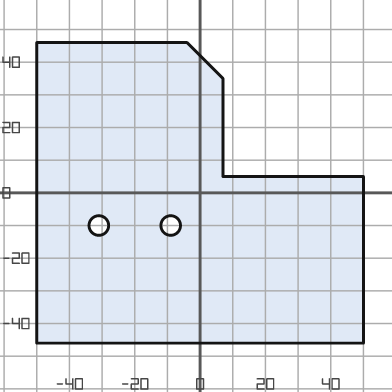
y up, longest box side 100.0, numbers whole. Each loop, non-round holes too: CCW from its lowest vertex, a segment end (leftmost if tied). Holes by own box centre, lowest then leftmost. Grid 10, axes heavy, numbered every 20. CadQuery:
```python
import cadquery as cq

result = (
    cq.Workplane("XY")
    .moveTo(-50.0, -46.0)
    .lineTo(50.0, -46.0)
    .lineTo(50.0, 5.0)
    .lineTo(7.0, 5.0)
    .lineTo(7.0, 35.0)
    .lineTo(-4.0, 46.0)
    .lineTo(-50.0, 46.0)
    .close()
    .moveTo(-31.0, -10.0)
    .circle(3.0)
    .moveTo(-9.0, -10.0)
    .circle(3.0)
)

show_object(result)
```